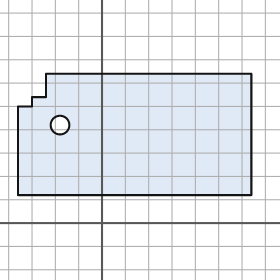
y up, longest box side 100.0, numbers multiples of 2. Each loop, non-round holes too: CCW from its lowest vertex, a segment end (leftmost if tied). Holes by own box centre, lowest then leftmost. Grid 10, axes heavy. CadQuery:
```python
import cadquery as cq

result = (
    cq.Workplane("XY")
    .moveTo(-36.0, 12.0)
    .lineTo(64.0, 12.0)
    .lineTo(64.0, 64.0)
    .lineTo(-24.0, 64.0)
    .lineTo(-24.0, 54.0)
    .lineTo(-30.0, 54.0)
    .lineTo(-30.0, 50.0)
    .lineTo(-36.0, 50.0)
    .close()
    .moveTo(-18.0, 42.0)
    .circle(4.0)
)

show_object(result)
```